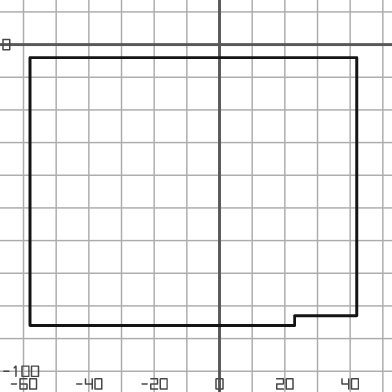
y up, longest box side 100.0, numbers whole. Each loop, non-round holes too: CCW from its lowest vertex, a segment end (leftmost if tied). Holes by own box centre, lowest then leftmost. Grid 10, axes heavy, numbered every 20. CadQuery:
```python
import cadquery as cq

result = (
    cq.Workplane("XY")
    .moveTo(-58.0, -86.0)
    .lineTo(23.0, -86.0)
    .lineTo(23.0, -83.0)
    .lineTo(42.0, -83.0)
    .lineTo(42.0, -4.0)
    .lineTo(-58.0, -4.0)
    .close()
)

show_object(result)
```